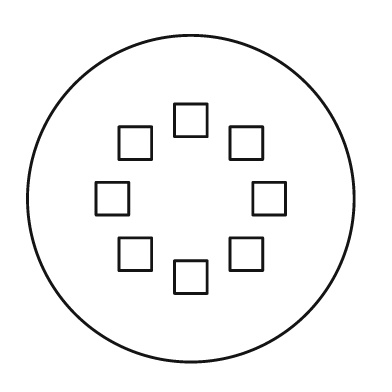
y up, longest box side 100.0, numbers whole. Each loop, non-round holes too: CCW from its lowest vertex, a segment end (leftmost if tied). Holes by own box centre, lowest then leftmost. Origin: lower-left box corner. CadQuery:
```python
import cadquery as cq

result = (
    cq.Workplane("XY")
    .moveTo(50.0, 50.0)
    .circle(50.0)
    .moveTo(45.0, 21.0)
    .lineTo(55.0, 21.0)
    .lineTo(55.0, 31.0)
    .lineTo(45.0, 31.0)
    .close()
    .moveTo(28.0, 28.0)
    .lineTo(38.0, 28.0)
    .lineTo(38.0, 38.0)
    .lineTo(28.0, 38.0)
    .close()
    .moveTo(62.0, 28.0)
    .lineTo(72.0, 28.0)
    .lineTo(72.0, 38.0)
    .lineTo(62.0, 38.0)
    .close()
    .moveTo(21.0, 45.0)
    .lineTo(31.0, 45.0)
    .lineTo(31.0, 55.0)
    .lineTo(21.0, 55.0)
    .close()
    .moveTo(69.0, 45.0)
    .lineTo(79.0, 45.0)
    .lineTo(79.0, 55.0)
    .lineTo(69.0, 55.0)
    .close()
    .moveTo(28.0, 62.0)
    .lineTo(38.0, 62.0)
    .lineTo(38.0, 72.0)
    .lineTo(28.0, 72.0)
    .close()
    .moveTo(62.0, 62.0)
    .lineTo(72.0, 62.0)
    .lineTo(72.0, 72.0)
    .lineTo(62.0, 72.0)
    .close()
    .moveTo(45.0, 69.0)
    .lineTo(55.0, 69.0)
    .lineTo(55.0, 79.0)
    .lineTo(45.0, 79.0)
    .close()
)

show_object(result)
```